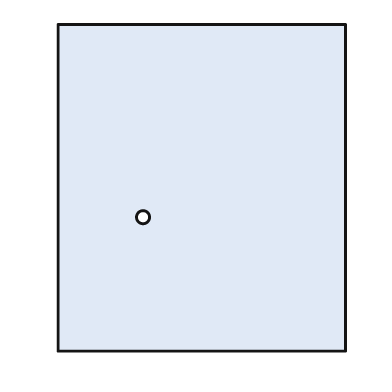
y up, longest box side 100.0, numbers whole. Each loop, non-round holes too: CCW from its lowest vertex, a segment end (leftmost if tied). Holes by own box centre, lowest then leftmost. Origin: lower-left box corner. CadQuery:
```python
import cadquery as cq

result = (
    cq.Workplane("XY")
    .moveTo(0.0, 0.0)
    .lineTo(88.0, 0.0)
    .lineTo(88.0, 100.0)
    .lineTo(0.0, 100.0)
    .close()
    .moveTo(26.0, 41.0)
    .circle(2.0)
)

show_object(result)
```